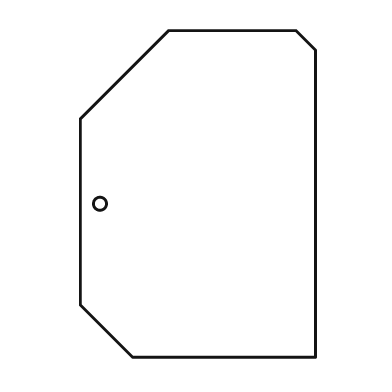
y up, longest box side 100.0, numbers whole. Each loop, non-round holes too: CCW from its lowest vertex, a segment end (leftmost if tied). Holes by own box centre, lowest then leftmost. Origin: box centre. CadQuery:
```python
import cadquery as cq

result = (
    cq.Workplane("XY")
    .moveTo(-20.0, -50.0)
    .lineTo(36.0, -50.0)
    .lineTo(36.0, 44.0)
    .lineTo(30.0, 50.0)
    .lineTo(-9.0, 50.0)
    .lineTo(-36.0, 23.0)
    .lineTo(-36.0, -34.0)
    .close()
    .moveTo(-30.0, -3.0)
    .circle(2.0)
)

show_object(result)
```